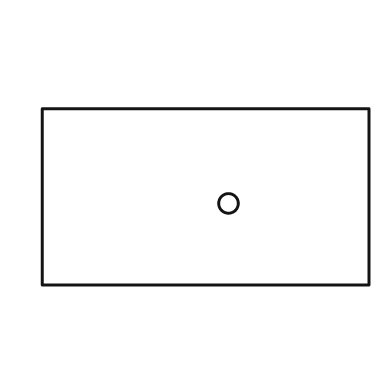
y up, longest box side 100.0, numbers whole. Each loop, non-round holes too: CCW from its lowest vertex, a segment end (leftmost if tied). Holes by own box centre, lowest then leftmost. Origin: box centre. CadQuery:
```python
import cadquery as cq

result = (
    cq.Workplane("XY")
    .moveTo(-50.0, -27.0)
    .lineTo(50.0, -27.0)
    .lineTo(50.0, 27.0)
    .lineTo(-50.0, 27.0)
    .close()
    .moveTo(7.0, -2.0)
    .circle(3.0)
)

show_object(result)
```